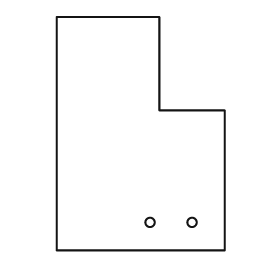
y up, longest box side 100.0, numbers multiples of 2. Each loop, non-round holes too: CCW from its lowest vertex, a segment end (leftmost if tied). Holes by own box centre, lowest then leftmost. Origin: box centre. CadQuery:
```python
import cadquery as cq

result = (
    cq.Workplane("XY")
    .moveTo(-36.0, -50.0)
    .lineTo(36.0, -50.0)
    .lineTo(36.0, 10.0)
    .lineTo(8.0, 10.0)
    .lineTo(8.0, 50.0)
    .lineTo(-36.0, 50.0)
    .close()
    .moveTo(4.0, -38.0)
    .circle(2.0)
    .moveTo(22.0, -38.0)
    .circle(2.0)
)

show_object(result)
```